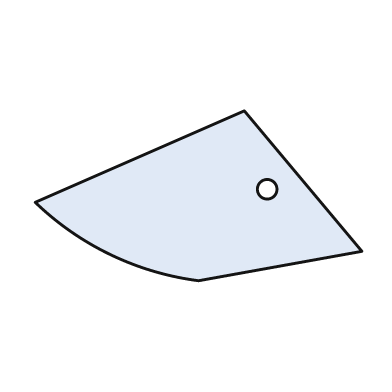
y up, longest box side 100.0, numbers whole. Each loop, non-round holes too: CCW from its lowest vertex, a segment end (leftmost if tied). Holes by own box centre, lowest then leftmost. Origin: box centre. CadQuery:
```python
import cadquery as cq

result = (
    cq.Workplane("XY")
    .moveTo(0.0, -26.0)
    .lineTo(50.0, -17.0)
    .lineTo(14.0, 26.0)
    .lineTo(-50.0, -2.0)
    .threePointArc((-27.0, -18.0), (0.0, -26.0))
    .close()
    .moveTo(21.0, 2.0)
    .circle(3.0)
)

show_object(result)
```